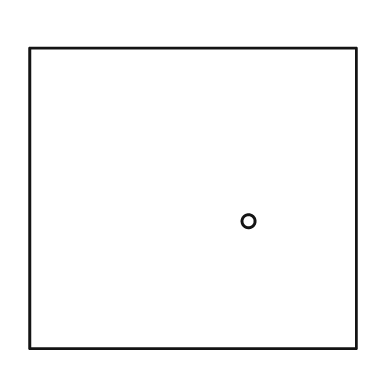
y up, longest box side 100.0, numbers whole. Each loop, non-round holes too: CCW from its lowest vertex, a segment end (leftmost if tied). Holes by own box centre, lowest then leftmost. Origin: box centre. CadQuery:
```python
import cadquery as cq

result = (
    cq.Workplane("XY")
    .moveTo(-50.0, -46.0)
    .lineTo(50.0, -46.0)
    .lineTo(50.0, 46.0)
    .lineTo(-50.0, 46.0)
    .close()
    .moveTo(17.0, -7.0)
    .circle(2.0)
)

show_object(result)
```